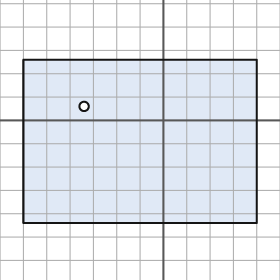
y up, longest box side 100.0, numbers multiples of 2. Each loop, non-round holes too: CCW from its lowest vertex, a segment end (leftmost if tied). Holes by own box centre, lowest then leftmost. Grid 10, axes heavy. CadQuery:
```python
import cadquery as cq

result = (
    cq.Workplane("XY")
    .moveTo(-60.0, -44.0)
    .lineTo(40.0, -44.0)
    .lineTo(40.0, 26.0)
    .lineTo(-60.0, 26.0)
    .close()
    .moveTo(-34.0, 6.0)
    .circle(2.0)
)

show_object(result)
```